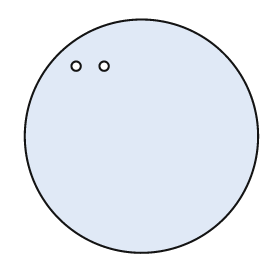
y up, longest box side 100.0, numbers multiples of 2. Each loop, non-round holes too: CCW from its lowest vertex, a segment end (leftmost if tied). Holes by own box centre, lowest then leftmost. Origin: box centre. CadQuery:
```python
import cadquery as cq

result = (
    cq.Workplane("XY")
    .moveTo(0.0, 0.0)
    .circle(50.0)
    .moveTo(-28.0, 30.0)
    .circle(2.0)
    .moveTo(-16.0, 30.0)
    .circle(2.0)
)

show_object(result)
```